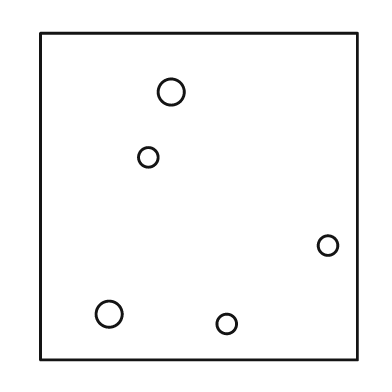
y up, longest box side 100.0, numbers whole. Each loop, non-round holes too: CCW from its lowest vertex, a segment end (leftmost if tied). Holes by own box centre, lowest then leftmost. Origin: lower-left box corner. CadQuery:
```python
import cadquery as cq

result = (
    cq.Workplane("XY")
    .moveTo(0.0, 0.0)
    .lineTo(97.0, 0.0)
    .lineTo(97.0, 100.0)
    .lineTo(0.0, 100.0)
    .close()
    .moveTo(57.0, 11.0)
    .circle(3.0)
    .moveTo(21.0, 14.0)
    .circle(4.0)
    .moveTo(88.0, 35.0)
    .circle(3.0)
    .moveTo(33.0, 62.0)
    .circle(3.0)
    .moveTo(40.0, 82.0)
    .circle(4.0)
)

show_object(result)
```